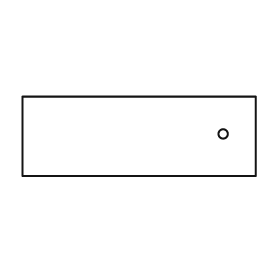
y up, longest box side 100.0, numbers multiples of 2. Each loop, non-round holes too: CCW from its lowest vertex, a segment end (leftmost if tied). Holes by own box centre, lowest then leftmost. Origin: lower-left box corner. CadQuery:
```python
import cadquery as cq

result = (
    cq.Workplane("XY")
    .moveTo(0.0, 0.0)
    .lineTo(100.0, 0.0)
    .lineTo(100.0, 34.0)
    .lineTo(0.0, 34.0)
    .close()
    .moveTo(86.0, 18.0)
    .circle(2.0)
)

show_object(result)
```